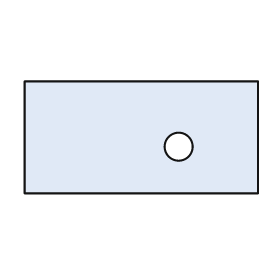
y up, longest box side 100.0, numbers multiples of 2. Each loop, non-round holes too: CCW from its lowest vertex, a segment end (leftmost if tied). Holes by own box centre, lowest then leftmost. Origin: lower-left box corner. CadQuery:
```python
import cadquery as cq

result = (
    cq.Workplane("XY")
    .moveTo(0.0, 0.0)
    .lineTo(100.0, 0.0)
    .lineTo(100.0, 48.0)
    .lineTo(0.0, 48.0)
    .close()
    .moveTo(66.0, 20.0)
    .circle(6.0)
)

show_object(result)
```